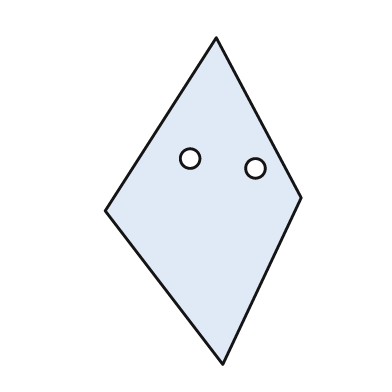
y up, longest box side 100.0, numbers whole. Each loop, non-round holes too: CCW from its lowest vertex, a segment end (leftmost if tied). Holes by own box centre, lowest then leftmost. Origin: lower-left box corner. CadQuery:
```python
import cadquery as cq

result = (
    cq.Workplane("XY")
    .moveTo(36.0, 0.0)
    .lineTo(60.0, 51.0)
    .lineTo(34.0, 100.0)
    .lineTo(0.0, 47.0)
    .close()
    .moveTo(46.0, 60.0)
    .circle(3.0)
    .moveTo(26.0, 63.0)
    .circle(3.0)
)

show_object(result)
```